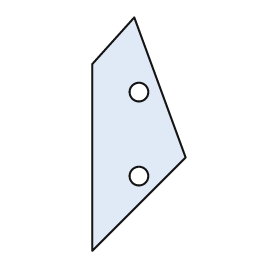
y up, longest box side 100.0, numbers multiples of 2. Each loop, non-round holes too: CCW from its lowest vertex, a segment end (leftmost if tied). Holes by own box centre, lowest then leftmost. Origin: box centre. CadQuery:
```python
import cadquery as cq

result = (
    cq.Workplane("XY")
    .moveTo(-20.0, -50.0)
    .lineTo(20.0, -10.0)
    .lineTo(-2.0, 50.0)
    .lineTo(-20.0, 30.0)
    .close()
    .moveTo(0.0, -18.0)
    .circle(4.0)
    .moveTo(0.0, 18.0)
    .circle(4.0)
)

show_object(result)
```